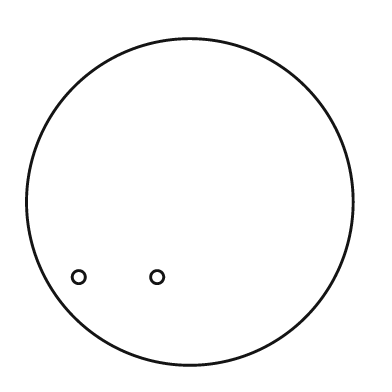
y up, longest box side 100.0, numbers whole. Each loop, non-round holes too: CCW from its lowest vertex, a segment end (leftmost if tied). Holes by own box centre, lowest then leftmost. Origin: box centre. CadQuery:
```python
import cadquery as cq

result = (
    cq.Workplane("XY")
    .moveTo(0.0, 0.0)
    .circle(50.0)
    .moveTo(-34.0, -23.0)
    .circle(2.0)
    .moveTo(-10.0, -23.0)
    .circle(2.0)
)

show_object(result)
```